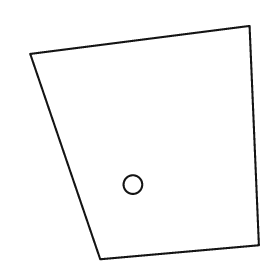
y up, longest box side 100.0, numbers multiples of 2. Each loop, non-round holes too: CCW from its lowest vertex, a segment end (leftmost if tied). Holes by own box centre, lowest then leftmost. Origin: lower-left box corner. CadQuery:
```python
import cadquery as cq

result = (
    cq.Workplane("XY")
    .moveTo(30.0, 0.0)
    .lineTo(98.0, 6.0)
    .lineTo(94.0, 100.0)
    .lineTo(0.0, 88.0)
    .close()
    .moveTo(44.0, 32.0)
    .circle(4.0)
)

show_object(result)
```